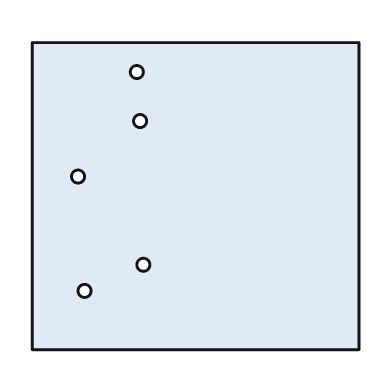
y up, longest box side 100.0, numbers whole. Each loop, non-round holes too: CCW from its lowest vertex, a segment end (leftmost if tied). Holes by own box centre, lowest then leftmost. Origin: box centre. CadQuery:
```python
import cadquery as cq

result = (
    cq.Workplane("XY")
    .moveTo(-50.0, -47.0)
    .lineTo(50.0, -47.0)
    .lineTo(50.0, 47.0)
    .lineTo(-50.0, 47.0)
    .close()
    .moveTo(-34.0, -29.0)
    .circle(2.0)
    .moveTo(-16.0, -21.0)
    .circle(2.0)
    .moveTo(-36.0, 6.0)
    .circle(2.0)
    .moveTo(-17.0, 23.0)
    .circle(2.0)
    .moveTo(-18.0, 38.0)
    .circle(2.0)
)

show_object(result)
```